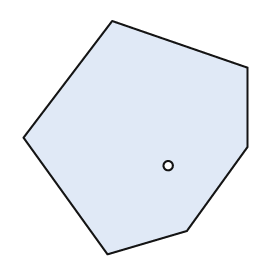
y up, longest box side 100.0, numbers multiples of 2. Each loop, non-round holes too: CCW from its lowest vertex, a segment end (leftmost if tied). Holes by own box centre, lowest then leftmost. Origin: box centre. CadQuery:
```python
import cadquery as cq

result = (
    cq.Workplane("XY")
    .moveTo(-12.0, -50.0)
    .lineTo(22.0, -40.0)
    .lineTo(48.0, -4.0)
    .lineTo(48.0, 30.0)
    .lineTo(-10.0, 50.0)
    .lineTo(-48.0, 0.0)
    .close()
    .moveTo(14.0, -12.0)
    .circle(2.0)
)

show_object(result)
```